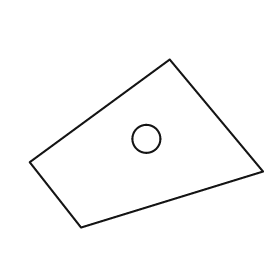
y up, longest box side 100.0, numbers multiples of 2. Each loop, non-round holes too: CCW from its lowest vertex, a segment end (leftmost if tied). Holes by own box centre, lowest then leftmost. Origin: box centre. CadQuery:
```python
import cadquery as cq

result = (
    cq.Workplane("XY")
    .moveTo(-28.0, -36.0)
    .lineTo(50.0, -12.0)
    .lineTo(10.0, 36.0)
    .lineTo(-50.0, -8.0)
    .close()
    .moveTo(0.0, 2.0)
    .circle(6.0)
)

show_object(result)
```